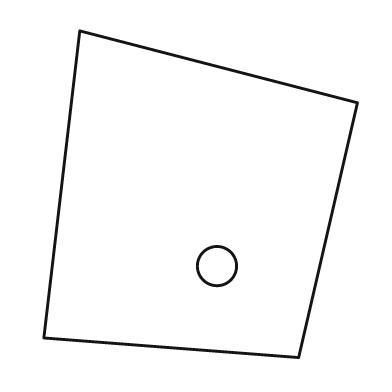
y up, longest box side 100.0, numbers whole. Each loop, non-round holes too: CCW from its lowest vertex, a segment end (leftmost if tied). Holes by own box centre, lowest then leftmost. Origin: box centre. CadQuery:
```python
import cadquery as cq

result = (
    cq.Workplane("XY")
    .moveTo(30.0, -50.0)
    .lineTo(48.0, 28.0)
    .lineTo(-37.0, 50.0)
    .lineTo(-48.0, -44.0)
    .close()
    .moveTo(5.0, -22.0)
    .circle(6.0)
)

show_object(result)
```